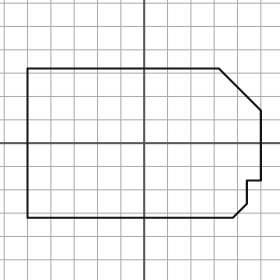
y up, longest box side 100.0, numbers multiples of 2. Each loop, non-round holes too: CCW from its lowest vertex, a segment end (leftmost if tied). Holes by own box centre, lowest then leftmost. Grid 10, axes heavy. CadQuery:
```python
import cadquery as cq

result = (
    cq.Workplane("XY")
    .moveTo(-50.0, -32.0)
    .lineTo(38.0, -32.0)
    .lineTo(44.0, -26.0)
    .lineTo(44.0, -16.0)
    .lineTo(50.0, -16.0)
    .lineTo(50.0, 14.0)
    .lineTo(32.0, 32.0)
    .lineTo(-50.0, 32.0)
    .close()
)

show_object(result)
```